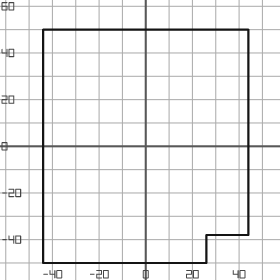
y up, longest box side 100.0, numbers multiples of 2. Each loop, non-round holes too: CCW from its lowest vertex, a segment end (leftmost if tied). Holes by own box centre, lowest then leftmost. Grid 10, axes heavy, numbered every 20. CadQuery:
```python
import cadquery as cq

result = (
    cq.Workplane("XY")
    .moveTo(-44.0, -50.0)
    .lineTo(26.0, -50.0)
    .lineTo(26.0, -38.0)
    .lineTo(44.0, -38.0)
    .lineTo(44.0, 50.0)
    .lineTo(-44.0, 50.0)
    .close()
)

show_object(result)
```